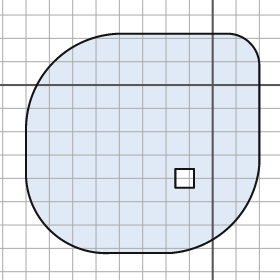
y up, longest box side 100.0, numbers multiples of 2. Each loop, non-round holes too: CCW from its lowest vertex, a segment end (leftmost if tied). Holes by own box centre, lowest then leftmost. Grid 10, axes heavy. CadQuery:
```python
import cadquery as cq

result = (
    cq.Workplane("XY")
    .moveTo(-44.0, -72.0)
    .lineTo(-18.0, -72.0)
    .threePointArc((8.0, -60.0), (20.0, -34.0))
    .lineTo(20.0, 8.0)
    .threePointArc((16.0, 18.0), (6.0, 22.0))
    .lineTo(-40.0, 22.0)
    .threePointArc((-68.0, 10.0), (-80.0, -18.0))
    .lineTo(-80.0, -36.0)
    .threePointArc((-70.0, -62.0), (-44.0, -72.0))
    .close()
    .moveTo(-16.0, -44.0)
    .lineTo(-8.0, -44.0)
    .lineTo(-8.0, -36.0)
    .lineTo(-16.0, -36.0)
    .close()
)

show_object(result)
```